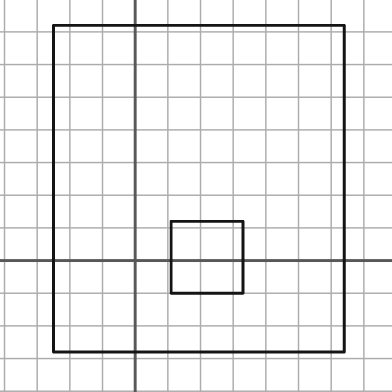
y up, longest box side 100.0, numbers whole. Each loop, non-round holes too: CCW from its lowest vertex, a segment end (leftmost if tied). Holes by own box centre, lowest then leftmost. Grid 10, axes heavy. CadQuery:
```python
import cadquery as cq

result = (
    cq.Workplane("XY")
    .moveTo(-25.0, -28.0)
    .lineTo(64.0, -28.0)
    .lineTo(64.0, 72.0)
    .lineTo(-25.0, 72.0)
    .close()
    .moveTo(11.0, -10.0)
    .lineTo(33.0, -10.0)
    .lineTo(33.0, 12.0)
    .lineTo(11.0, 12.0)
    .close()
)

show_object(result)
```